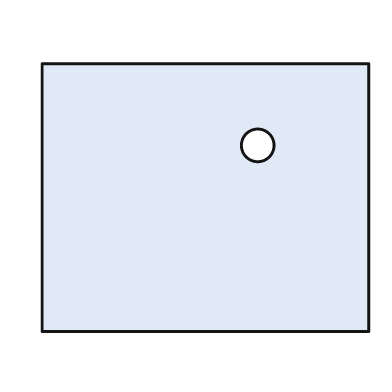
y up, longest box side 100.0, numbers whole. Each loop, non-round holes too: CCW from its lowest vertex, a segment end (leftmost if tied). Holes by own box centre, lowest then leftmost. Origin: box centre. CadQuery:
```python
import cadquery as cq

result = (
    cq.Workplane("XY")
    .moveTo(-50.0, -41.0)
    .lineTo(50.0, -41.0)
    .lineTo(50.0, 41.0)
    .lineTo(-50.0, 41.0)
    .close()
    .moveTo(16.0, 16.0)
    .circle(5.0)
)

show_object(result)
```